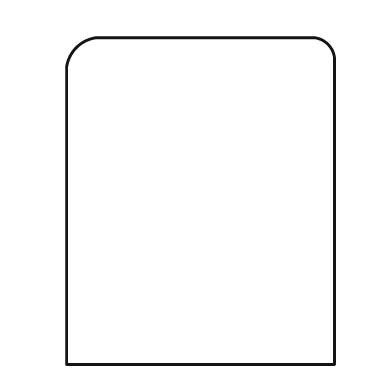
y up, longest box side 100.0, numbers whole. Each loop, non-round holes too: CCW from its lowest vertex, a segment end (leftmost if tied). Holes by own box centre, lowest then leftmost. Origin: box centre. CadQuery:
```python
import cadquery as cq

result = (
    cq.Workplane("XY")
    .moveTo(-41.0, -50.0)
    .lineTo(41.0, -50.0)
    .lineTo(41.0, 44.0)
    .threePointArc((39.0, 48.0), (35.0, 50.0))
    .lineTo(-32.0, 50.0)
    .threePointArc((-38.0, 47.0), (-41.0, 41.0))
    .close()
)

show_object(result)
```